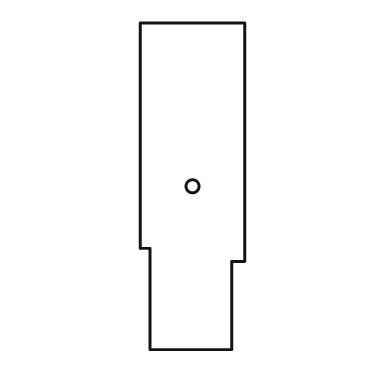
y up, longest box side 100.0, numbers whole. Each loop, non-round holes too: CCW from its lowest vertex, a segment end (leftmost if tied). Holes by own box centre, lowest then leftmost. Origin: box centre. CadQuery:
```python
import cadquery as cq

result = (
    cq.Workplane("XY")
    .moveTo(-13.0, -50.0)
    .lineTo(12.0, -50.0)
    .lineTo(12.0, -23.0)
    .lineTo(16.0, -23.0)
    .lineTo(16.0, 50.0)
    .lineTo(-16.0, 50.0)
    .lineTo(-16.0, -19.0)
    .lineTo(-13.0, -19.0)
    .close()
    .moveTo(0.0, 0.0)
    .circle(2.0)
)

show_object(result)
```